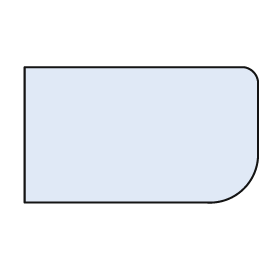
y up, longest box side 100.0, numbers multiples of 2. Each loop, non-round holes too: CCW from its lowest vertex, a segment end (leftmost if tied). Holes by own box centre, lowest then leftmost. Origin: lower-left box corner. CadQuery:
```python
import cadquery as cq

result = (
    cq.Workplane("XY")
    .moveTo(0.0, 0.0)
    .lineTo(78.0, 0.0)
    .threePointArc((94.0, 6.0), (100.0, 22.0))
    .lineTo(100.0, 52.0)
    .threePointArc((98.0, 56.0), (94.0, 58.0))
    .lineTo(0.0, 58.0)
    .close()
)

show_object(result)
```